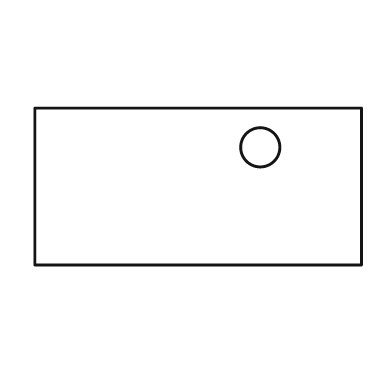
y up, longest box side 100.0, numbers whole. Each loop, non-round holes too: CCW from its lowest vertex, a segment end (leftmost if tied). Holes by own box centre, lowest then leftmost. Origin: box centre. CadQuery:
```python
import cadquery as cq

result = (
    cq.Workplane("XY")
    .moveTo(-50.0, -24.0)
    .lineTo(50.0, -24.0)
    .lineTo(50.0, 24.0)
    .lineTo(-50.0, 24.0)
    .close()
    .moveTo(19.0, 12.0)
    .circle(6.0)
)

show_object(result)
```